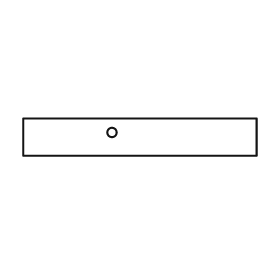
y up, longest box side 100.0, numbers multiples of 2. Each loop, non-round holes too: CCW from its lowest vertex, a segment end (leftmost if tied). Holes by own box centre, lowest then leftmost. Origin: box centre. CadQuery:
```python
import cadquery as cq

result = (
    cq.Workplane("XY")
    .moveTo(-50.0, -8.0)
    .lineTo(50.0, -8.0)
    .lineTo(50.0, 8.0)
    .lineTo(-50.0, 8.0)
    .close()
    .moveTo(-12.0, 2.0)
    .circle(2.0)
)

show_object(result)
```